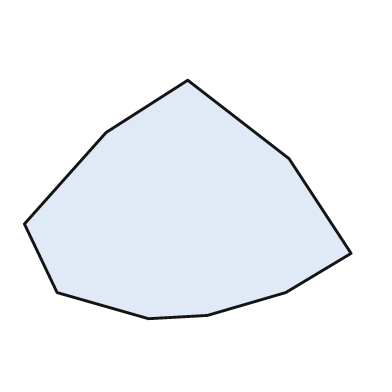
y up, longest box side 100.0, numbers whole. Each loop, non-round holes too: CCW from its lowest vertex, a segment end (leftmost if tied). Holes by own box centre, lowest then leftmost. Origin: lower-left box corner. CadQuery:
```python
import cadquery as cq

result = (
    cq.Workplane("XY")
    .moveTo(38.0, 0.0)
    .lineTo(56.0, 1.0)
    .lineTo(80.0, 8.0)
    .lineTo(100.0, 20.0)
    .lineTo(81.0, 49.0)
    .lineTo(50.0, 73.0)
    .lineTo(25.0, 57.0)
    .lineTo(0.0, 29.0)
    .lineTo(10.0, 8.0)
    .close()
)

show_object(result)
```